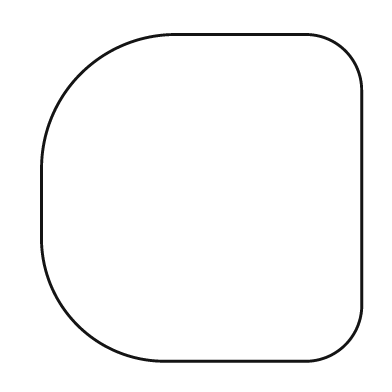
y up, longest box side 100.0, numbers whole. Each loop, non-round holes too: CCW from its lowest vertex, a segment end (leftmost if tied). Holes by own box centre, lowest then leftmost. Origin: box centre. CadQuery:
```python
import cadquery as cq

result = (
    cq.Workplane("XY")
    .moveTo(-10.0, -50.0)
    .lineTo(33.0, -50.0)
    .threePointArc((44.0, -45.0), (49.0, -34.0))
    .lineTo(49.0, 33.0)
    .threePointArc((44.0, 45.0), (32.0, 50.0))
    .lineTo(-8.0, 50.0)
    .threePointArc((-37.0, 38.0), (-49.0, 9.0))
    .lineTo(-49.0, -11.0)
    .threePointArc((-38.0, -39.0), (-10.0, -50.0))
    .close()
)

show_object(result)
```